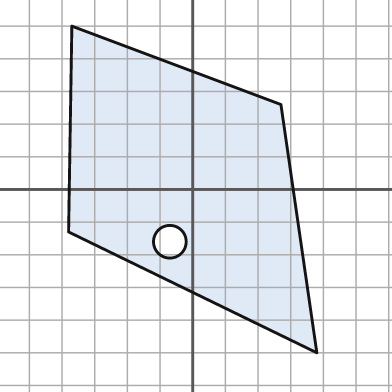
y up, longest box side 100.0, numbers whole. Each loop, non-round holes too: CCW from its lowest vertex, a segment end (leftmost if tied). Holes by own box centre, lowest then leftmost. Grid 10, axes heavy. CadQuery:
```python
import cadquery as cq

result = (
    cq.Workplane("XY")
    .moveTo(38.0, -50.0)
    .lineTo(27.0, 26.0)
    .lineTo(-37.0, 50.0)
    .lineTo(-38.0, -13.0)
    .close()
    .moveTo(-7.0, -16.0)
    .circle(5.0)
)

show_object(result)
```